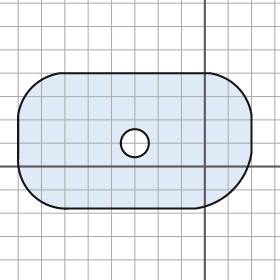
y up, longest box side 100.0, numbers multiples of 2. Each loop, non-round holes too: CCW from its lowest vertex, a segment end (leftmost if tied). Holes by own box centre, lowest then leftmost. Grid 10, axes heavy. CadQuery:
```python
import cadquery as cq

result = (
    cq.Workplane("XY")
    .moveTo(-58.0, -18.0)
    .lineTo(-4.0, -18.0)
    .threePointArc((12.0, -10.0), (20.0, 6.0))
    .lineTo(20.0, 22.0)
    .threePointArc((14.0, 34.0), (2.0, 40.0))
    .lineTo(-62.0, 40.0)
    .threePointArc((-74.0, 34.0), (-80.0, 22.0))
    .lineTo(-80.0, 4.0)
    .threePointArc((-74.0, -12.0), (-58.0, -18.0))
    .close()
    .moveTo(-30.0, 10.0)
    .circle(6.0)
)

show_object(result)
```